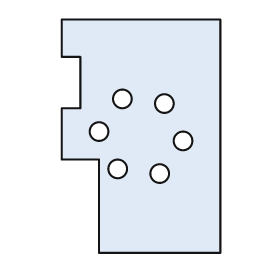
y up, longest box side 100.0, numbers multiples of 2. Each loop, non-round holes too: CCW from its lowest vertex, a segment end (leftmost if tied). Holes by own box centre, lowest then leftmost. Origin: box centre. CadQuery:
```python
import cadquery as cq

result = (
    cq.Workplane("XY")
    .moveTo(-18.0, -50.0)
    .lineTo(34.0, -50.0)
    .lineTo(34.0, 50.0)
    .lineTo(-34.0, 50.0)
    .lineTo(-34.0, 34.0)
    .lineTo(-26.0, 34.0)
    .lineTo(-26.0, 12.0)
    .lineTo(-34.0, 12.0)
    .lineTo(-34.0, -10.0)
    .lineTo(-18.0, -10.0)
    .close()
    .moveTo(8.0, -16.0)
    .circle(4.0)
    .moveTo(-10.0, -14.0)
    .circle(4.0)
    .moveTo(18.0, -2.0)
    .circle(4.0)
    .moveTo(-18.0, 2.0)
    .circle(4.0)
    .moveTo(10.0, 14.0)
    .circle(4.0)
    .moveTo(-8.0, 16.0)
    .circle(4.0)
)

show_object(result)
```